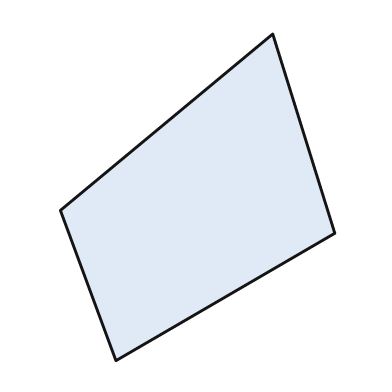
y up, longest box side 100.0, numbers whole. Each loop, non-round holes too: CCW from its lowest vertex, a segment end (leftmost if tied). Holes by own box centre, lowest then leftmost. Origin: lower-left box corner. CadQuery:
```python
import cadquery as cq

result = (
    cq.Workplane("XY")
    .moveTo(17.0, 0.0)
    .lineTo(84.0, 39.0)
    .lineTo(65.0, 100.0)
    .lineTo(0.0, 46.0)
    .close()
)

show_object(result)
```